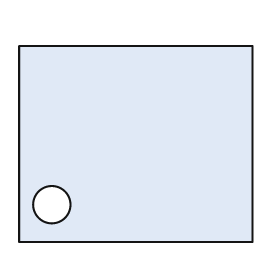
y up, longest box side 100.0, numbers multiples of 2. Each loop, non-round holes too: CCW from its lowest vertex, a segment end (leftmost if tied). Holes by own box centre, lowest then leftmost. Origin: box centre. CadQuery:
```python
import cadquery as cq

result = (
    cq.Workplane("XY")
    .moveTo(-50.0, -42.0)
    .lineTo(50.0, -42.0)
    .lineTo(50.0, 42.0)
    .lineTo(-50.0, 42.0)
    .close()
    .moveTo(-36.0, -26.0)
    .circle(8.0)
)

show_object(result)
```